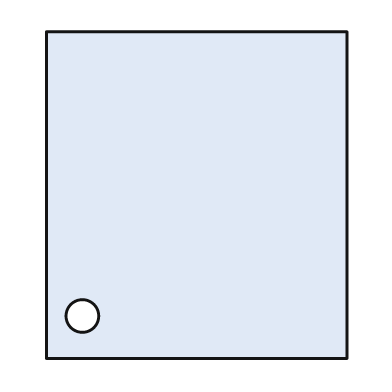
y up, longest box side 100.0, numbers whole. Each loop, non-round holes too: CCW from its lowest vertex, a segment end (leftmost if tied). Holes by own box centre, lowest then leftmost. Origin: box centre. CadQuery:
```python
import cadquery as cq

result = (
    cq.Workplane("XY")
    .moveTo(-46.0, -50.0)
    .lineTo(46.0, -50.0)
    .lineTo(46.0, 50.0)
    .lineTo(-46.0, 50.0)
    .close()
    .moveTo(-35.0, -37.0)
    .circle(5.0)
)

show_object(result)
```